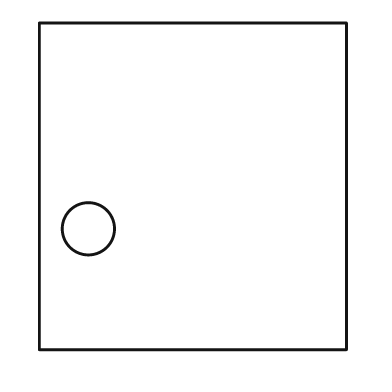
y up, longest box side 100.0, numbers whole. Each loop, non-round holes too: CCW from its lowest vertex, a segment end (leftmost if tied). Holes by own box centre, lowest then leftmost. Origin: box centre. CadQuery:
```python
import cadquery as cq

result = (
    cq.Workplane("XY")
    .moveTo(-47.0, -50.0)
    .lineTo(47.0, -50.0)
    .lineTo(47.0, 50.0)
    .lineTo(-47.0, 50.0)
    .close()
    .moveTo(-32.0, -13.0)
    .circle(8.0)
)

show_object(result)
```